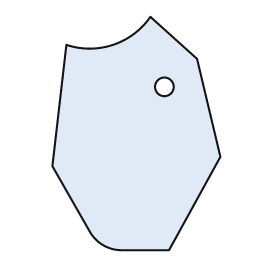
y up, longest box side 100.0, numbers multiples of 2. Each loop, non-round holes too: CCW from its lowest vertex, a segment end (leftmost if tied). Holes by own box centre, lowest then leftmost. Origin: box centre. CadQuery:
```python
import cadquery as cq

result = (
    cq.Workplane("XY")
    .moveTo(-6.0, -50.0)
    .lineTo(14.0, -50.0)
    .lineTo(36.0, -10.0)
    .lineTo(26.0, 32.0)
    .lineTo(6.0, 50.0)
    .threePointArc((-10.0, 38.0), (-30.0, 38.0))
    .lineTo(-36.0, -14.0)
    .lineTo(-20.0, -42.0)
    .threePointArc((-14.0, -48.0), (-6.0, -50.0))
    .close()
    .moveTo(12.0, 20.0)
    .circle(4.0)
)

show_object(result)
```